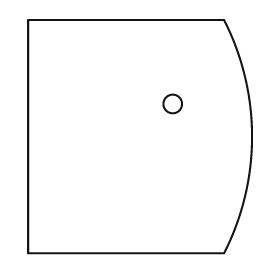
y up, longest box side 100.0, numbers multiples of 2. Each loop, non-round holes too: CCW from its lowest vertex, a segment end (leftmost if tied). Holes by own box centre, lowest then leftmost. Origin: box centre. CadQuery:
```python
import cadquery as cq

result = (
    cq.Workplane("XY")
    .moveTo(-48.0, -50.0)
    .lineTo(36.0, -50.0)
    .threePointArc((48.0, 0.0), (36.0, 50.0))
    .lineTo(-48.0, 50.0)
    .close()
    .moveTo(14.0, 14.0)
    .circle(4.0)
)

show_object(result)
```